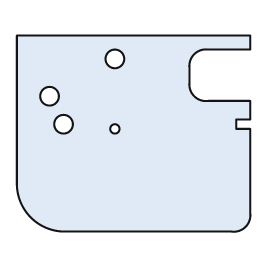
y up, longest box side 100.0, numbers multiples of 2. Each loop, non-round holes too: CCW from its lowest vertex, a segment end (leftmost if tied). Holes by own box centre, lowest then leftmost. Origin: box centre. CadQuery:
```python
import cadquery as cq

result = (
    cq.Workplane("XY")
    .moveTo(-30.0, -42.0)
    .lineTo(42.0, -42.0)
    .threePointArc((48.0, -40.0), (50.0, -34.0))
    .lineTo(50.0, 2.0)
    .lineTo(44.0, 2.0)
    .lineTo(44.0, 6.0)
    .lineTo(50.0, 6.0)
    .lineTo(50.0, 14.0)
    .lineTo(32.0, 14.0)
    .threePointArc((26.0, 16.0), (24.0, 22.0))
    .lineTo(24.0, 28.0)
    .threePointArc((26.0, 34.0), (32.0, 36.0))
    .lineTo(50.0, 36.0)
    .lineTo(50.0, 42.0)
    .lineTo(-50.0, 42.0)
    .lineTo(-50.0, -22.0)
    .threePointArc((-44.0, -36.0), (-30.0, -42.0))
    .close()
    .moveTo(-8.0, 2.0)
    .circle(2.0)
    .moveTo(-30.0, 4.0)
    .circle(4.0)
    .moveTo(-36.0, 16.0)
    .circle(4.0)
    .moveTo(-8.0, 32.0)
    .circle(4.0)
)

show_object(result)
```